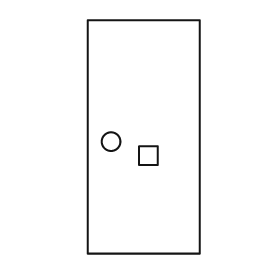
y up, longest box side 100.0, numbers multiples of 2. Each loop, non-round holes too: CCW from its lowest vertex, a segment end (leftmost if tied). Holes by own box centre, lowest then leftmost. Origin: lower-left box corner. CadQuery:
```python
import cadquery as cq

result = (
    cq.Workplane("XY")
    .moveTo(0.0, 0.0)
    .lineTo(48.0, 0.0)
    .lineTo(48.0, 100.0)
    .lineTo(0.0, 100.0)
    .close()
    .moveTo(22.0, 38.0)
    .lineTo(30.0, 38.0)
    .lineTo(30.0, 46.0)
    .lineTo(22.0, 46.0)
    .close()
    .moveTo(10.0, 48.0)
    .circle(4.0)
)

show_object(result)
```